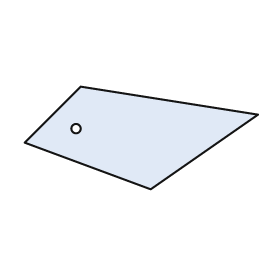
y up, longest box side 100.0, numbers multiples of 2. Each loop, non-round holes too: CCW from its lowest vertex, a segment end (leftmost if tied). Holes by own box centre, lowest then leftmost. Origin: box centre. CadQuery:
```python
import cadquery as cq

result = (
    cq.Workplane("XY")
    .moveTo(4.0, -22.0)
    .lineTo(50.0, 10.0)
    .lineTo(-26.0, 22.0)
    .lineTo(-50.0, -2.0)
    .close()
    .moveTo(-28.0, 4.0)
    .circle(2.0)
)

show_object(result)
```